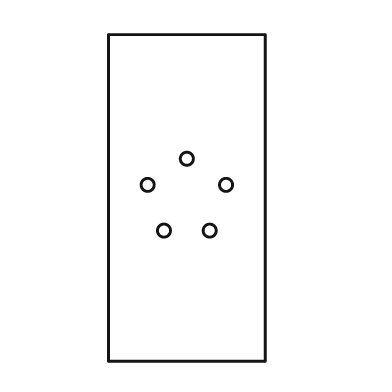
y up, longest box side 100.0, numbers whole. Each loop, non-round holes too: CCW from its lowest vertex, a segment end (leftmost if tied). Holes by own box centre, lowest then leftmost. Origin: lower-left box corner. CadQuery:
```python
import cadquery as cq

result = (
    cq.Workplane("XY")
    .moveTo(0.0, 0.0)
    .lineTo(48.0, 0.0)
    .lineTo(48.0, 100.0)
    .lineTo(0.0, 100.0)
    .close()
    .moveTo(17.0, 40.0)
    .circle(2.0)
    .moveTo(31.0, 40.0)
    .circle(2.0)
    .moveTo(12.0, 54.0)
    .circle(2.0)
    .moveTo(36.0, 54.0)
    .circle(2.0)
    .moveTo(24.0, 62.0)
    .circle(2.0)
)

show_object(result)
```